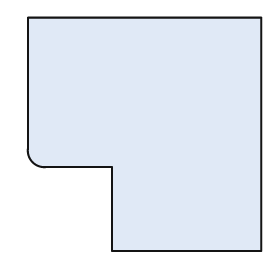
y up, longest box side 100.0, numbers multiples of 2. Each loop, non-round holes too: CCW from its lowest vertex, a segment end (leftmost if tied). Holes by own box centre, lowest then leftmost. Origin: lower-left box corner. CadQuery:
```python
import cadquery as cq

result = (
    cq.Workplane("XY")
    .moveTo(36.0, 0.0)
    .lineTo(100.0, 0.0)
    .lineTo(100.0, 100.0)
    .lineTo(0.0, 100.0)
    .lineTo(0.0, 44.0)
    .threePointArc((2.0, 38.0), (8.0, 36.0))
    .lineTo(36.0, 36.0)
    .close()
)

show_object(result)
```